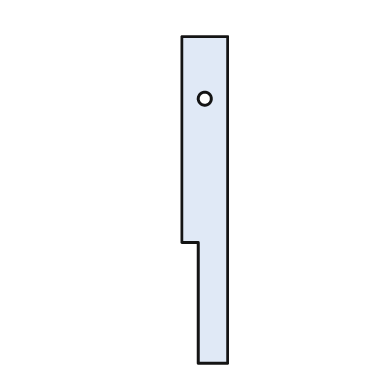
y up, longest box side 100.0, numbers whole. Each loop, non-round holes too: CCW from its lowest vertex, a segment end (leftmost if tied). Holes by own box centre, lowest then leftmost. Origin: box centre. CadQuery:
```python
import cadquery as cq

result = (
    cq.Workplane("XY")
    .moveTo(-2.0, -50.0)
    .lineTo(7.0, -50.0)
    .lineTo(7.0, 50.0)
    .lineTo(-7.0, 50.0)
    .lineTo(-7.0, -13.0)
    .lineTo(-2.0, -13.0)
    .close()
    .moveTo(0.0, 31.0)
    .circle(2.0)
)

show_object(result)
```